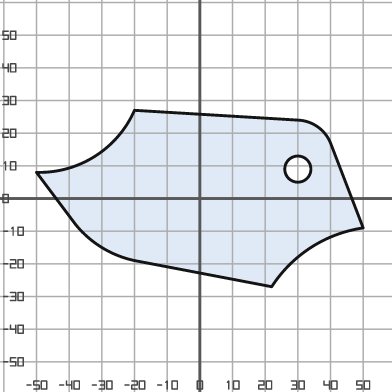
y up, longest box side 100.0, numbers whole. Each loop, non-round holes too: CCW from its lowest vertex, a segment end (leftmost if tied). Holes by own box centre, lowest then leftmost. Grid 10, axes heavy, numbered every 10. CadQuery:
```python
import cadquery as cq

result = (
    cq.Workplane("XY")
    .moveTo(22.0, -27.0)
    .threePointArc((34.0, -15.0), (50.0, -9.0))
    .lineTo(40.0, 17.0)
    .threePointArc((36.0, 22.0), (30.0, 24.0))
    .lineTo(-20.0, 27.0)
    .threePointArc((-32.0, 13.0), (-50.0, 8.0))
    .lineTo(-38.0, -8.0)
    .threePointArc((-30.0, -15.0), (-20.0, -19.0))
    .close()
    .moveTo(30.0, 9.0)
    .circle(4.0)
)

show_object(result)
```